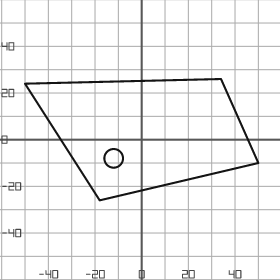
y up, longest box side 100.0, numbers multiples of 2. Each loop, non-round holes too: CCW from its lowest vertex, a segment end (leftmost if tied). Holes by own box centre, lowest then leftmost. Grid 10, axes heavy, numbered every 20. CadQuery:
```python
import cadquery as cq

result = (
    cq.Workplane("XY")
    .moveTo(-18.0, -26.0)
    .lineTo(50.0, -10.0)
    .lineTo(34.0, 26.0)
    .lineTo(-50.0, 24.0)
    .close()
    .moveTo(-12.0, -8.0)
    .circle(4.0)
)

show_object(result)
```